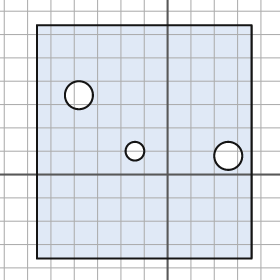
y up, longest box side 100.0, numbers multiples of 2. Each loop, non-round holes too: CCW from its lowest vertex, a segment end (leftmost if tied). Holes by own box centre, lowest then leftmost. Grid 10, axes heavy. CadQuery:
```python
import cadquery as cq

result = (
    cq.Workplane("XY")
    .moveTo(-56.0, -36.0)
    .lineTo(36.0, -36.0)
    .lineTo(36.0, 64.0)
    .lineTo(-56.0, 64.0)
    .close()
    .moveTo(26.0, 8.0)
    .circle(6.0)
    .moveTo(-14.0, 10.0)
    .circle(4.0)
    .moveTo(-38.0, 34.0)
    .circle(6.0)
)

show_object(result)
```